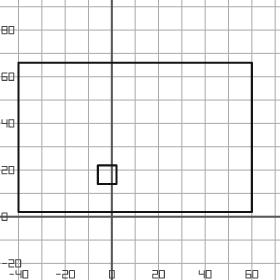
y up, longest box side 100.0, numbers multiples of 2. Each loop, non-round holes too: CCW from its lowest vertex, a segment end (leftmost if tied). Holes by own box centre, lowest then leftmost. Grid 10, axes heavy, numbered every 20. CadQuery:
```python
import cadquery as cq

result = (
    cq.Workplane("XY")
    .moveTo(-40.0, 2.0)
    .lineTo(60.0, 2.0)
    .lineTo(60.0, 66.0)
    .lineTo(-40.0, 66.0)
    .close()
    .moveTo(-6.0, 14.0)
    .lineTo(2.0, 14.0)
    .lineTo(2.0, 22.0)
    .lineTo(-6.0, 22.0)
    .close()
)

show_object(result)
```